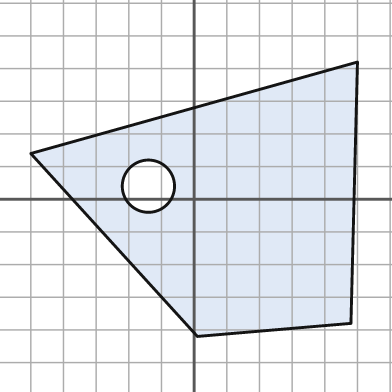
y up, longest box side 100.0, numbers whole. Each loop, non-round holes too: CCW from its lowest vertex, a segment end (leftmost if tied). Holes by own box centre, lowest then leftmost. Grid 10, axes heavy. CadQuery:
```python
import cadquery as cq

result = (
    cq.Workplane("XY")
    .moveTo(1.0, -42.0)
    .lineTo(48.0, -38.0)
    .lineTo(50.0, 42.0)
    .lineTo(-50.0, 14.0)
    .close()
    .moveTo(-14.0, 4.0)
    .circle(8.0)
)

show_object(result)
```